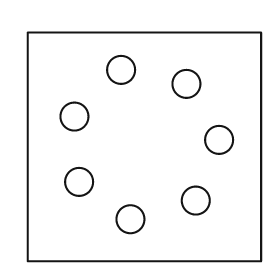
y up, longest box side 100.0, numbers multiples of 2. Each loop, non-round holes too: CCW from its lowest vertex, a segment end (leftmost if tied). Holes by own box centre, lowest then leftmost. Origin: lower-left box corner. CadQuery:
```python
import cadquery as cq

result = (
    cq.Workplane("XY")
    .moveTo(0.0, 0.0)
    .lineTo(100.0, 0.0)
    .lineTo(100.0, 98.0)
    .lineTo(0.0, 98.0)
    .close()
    .moveTo(44.0, 18.0)
    .circle(6.0)
    .moveTo(72.0, 26.0)
    .circle(6.0)
    .moveTo(22.0, 34.0)
    .circle(6.0)
    .moveTo(82.0, 52.0)
    .circle(6.0)
    .moveTo(20.0, 62.0)
    .circle(6.0)
    .moveTo(68.0, 76.0)
    .circle(6.0)
    .moveTo(40.0, 82.0)
    .circle(6.0)
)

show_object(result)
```